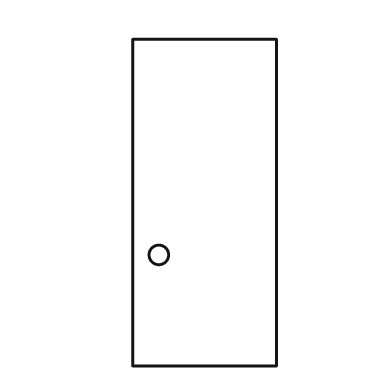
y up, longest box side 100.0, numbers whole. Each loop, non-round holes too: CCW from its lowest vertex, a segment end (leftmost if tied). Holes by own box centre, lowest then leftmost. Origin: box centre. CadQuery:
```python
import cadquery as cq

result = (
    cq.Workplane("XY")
    .moveTo(-22.0, -50.0)
    .lineTo(22.0, -50.0)
    .lineTo(22.0, 50.0)
    .lineTo(-22.0, 50.0)
    .close()
    .moveTo(-14.0, -16.0)
    .circle(3.0)
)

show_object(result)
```